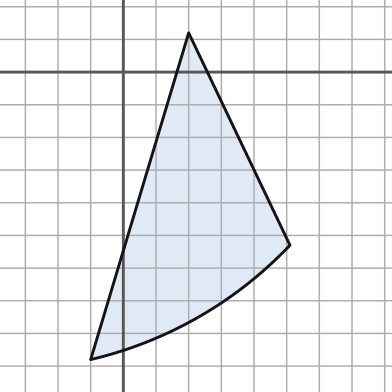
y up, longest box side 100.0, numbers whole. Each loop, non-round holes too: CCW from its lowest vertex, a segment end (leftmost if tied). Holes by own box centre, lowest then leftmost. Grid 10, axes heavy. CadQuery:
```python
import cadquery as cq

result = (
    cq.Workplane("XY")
    .moveTo(-10.0, -88.0)
    .threePointArc((23.0, -75.0), (51.0, -53.0))
    .lineTo(20.0, 12.0)
    .close()
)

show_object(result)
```